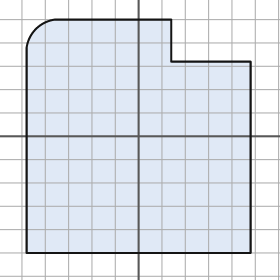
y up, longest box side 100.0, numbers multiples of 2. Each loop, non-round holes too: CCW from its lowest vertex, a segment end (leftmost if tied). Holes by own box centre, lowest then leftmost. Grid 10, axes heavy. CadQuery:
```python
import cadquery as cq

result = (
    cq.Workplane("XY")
    .moveTo(-48.0, -50.0)
    .lineTo(48.0, -50.0)
    .lineTo(48.0, 32.0)
    .lineTo(14.0, 32.0)
    .lineTo(14.0, 50.0)
    .lineTo(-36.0, 50.0)
    .threePointArc((-44.0, 46.0), (-48.0, 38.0))
    .close()
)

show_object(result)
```